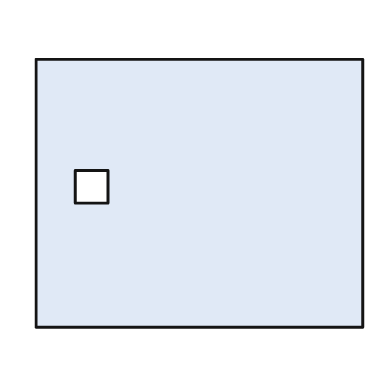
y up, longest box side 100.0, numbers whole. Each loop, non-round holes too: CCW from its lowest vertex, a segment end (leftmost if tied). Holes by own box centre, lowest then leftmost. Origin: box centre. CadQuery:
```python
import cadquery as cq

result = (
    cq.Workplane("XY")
    .moveTo(-50.0, -41.0)
    .lineTo(50.0, -41.0)
    .lineTo(50.0, 41.0)
    .lineTo(-50.0, 41.0)
    .close()
    .moveTo(-38.0, -3.0)
    .lineTo(-28.0, -3.0)
    .lineTo(-28.0, 7.0)
    .lineTo(-38.0, 7.0)
    .close()
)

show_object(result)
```